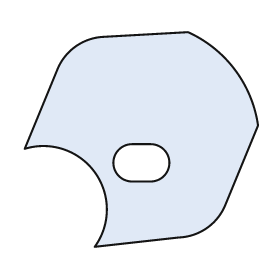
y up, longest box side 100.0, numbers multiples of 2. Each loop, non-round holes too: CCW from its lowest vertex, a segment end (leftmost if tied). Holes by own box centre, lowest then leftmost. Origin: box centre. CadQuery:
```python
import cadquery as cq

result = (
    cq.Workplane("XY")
    .moveTo(-20.0, -46.0)
    .lineTo(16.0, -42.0)
    .threePointArc((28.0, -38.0), (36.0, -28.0))
    .lineTo(50.0, 6.0)
    .threePointArc((40.0, 30.0), (20.0, 46.0))
    .lineTo(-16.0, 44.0)
    .threePointArc((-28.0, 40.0), (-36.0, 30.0))
    .lineTo(-50.0, -4.0)
    .threePointArc((-20.0, -14.0), (-20.0, -46.0))
    .close()
    .moveTo(-4.0, -18.0)
    .lineTo(4.0, -18.0)
    .threePointArc((12.0, -10.0), (4.0, -2.0))
    .lineTo(-4.0, -2.0)
    .threePointArc((-12.0, -10.0), (-4.0, -18.0))
    .close()
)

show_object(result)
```